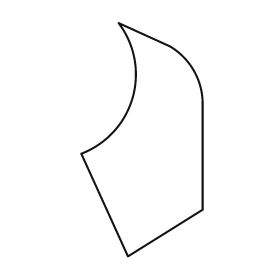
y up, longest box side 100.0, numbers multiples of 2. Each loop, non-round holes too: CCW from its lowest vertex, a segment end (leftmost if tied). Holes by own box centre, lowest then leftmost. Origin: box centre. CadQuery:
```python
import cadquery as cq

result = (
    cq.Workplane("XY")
    .moveTo(-6.0, -50.0)
    .lineTo(26.0, -30.0)
    .lineTo(26.0, 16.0)
    .threePointArc((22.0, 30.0), (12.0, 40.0))
    .lineTo(-10.0, 50.0)
    .threePointArc((-4.0, 18.0), (-26.0, -6.0))
    .close()
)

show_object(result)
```